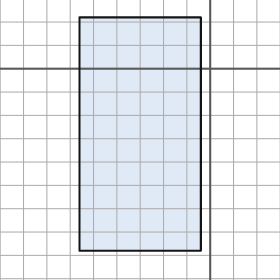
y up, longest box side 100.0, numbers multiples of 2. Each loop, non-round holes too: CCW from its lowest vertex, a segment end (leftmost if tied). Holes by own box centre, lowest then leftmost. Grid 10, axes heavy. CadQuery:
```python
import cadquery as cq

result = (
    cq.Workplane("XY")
    .moveTo(-56.0, -78.0)
    .lineTo(-4.0, -78.0)
    .lineTo(-4.0, 22.0)
    .lineTo(-56.0, 22.0)
    .close()
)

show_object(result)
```